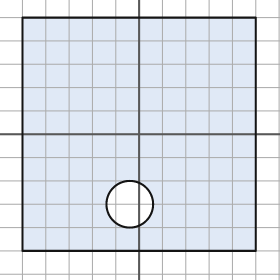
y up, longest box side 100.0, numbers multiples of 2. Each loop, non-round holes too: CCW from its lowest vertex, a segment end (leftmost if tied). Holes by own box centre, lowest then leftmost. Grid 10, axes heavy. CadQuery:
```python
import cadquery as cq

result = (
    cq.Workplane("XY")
    .moveTo(-50.0, -50.0)
    .lineTo(50.0, -50.0)
    .lineTo(50.0, 50.0)
    .lineTo(-50.0, 50.0)
    .close()
    .moveTo(-4.0, -30.0)
    .circle(10.0)
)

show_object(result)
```